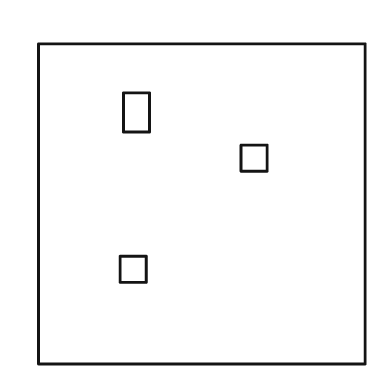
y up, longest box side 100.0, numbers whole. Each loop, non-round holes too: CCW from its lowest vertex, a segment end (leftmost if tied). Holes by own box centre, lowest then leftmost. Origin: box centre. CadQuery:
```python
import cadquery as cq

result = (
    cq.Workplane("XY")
    .moveTo(-50.0, -49.0)
    .lineTo(50.0, -49.0)
    .lineTo(50.0, 49.0)
    .lineTo(-50.0, 49.0)
    .close()
    .moveTo(-25.0, -24.0)
    .lineTo(-17.0, -24.0)
    .lineTo(-17.0, -16.0)
    .lineTo(-25.0, -16.0)
    .close()
    .moveTo(12.0, 10.0)
    .lineTo(20.0, 10.0)
    .lineTo(20.0, 18.0)
    .lineTo(12.0, 18.0)
    .close()
    .moveTo(-24.0, 22.0)
    .lineTo(-16.0, 22.0)
    .lineTo(-16.0, 34.0)
    .lineTo(-24.0, 34.0)
    .close()
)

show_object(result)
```